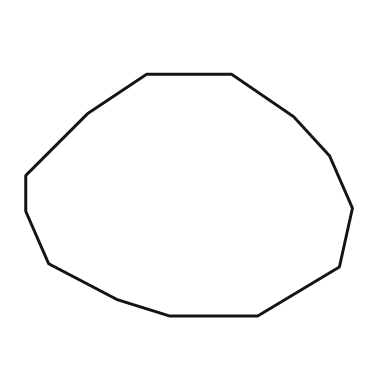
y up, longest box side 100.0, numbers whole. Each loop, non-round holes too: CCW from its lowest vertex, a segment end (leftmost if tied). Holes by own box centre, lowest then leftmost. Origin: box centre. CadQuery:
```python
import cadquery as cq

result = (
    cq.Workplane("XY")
    .moveTo(-6.0, -37.0)
    .lineTo(21.0, -37.0)
    .lineTo(46.0, -22.0)
    .lineTo(50.0, -4.0)
    .lineTo(43.0, 12.0)
    .lineTo(32.0, 24.0)
    .lineTo(13.0, 37.0)
    .lineTo(-13.0, 37.0)
    .lineTo(-31.0, 25.0)
    .lineTo(-50.0, 6.0)
    .lineTo(-50.0, -5.0)
    .lineTo(-43.0, -21.0)
    .lineTo(-22.0, -32.0)
    .close()
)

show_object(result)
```